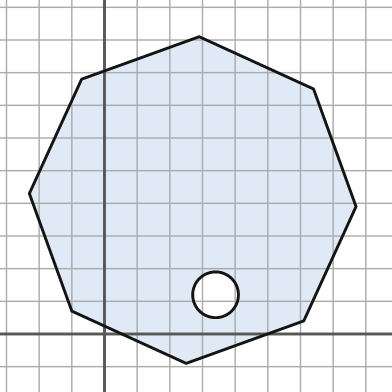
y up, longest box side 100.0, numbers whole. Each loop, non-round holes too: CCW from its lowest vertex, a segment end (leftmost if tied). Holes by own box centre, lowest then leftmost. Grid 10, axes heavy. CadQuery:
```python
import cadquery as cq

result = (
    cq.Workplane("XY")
    .moveTo(25.0, -9.0)
    .lineTo(61.0, 4.0)
    .lineTo(77.0, 39.0)
    .lineTo(64.0, 75.0)
    .lineTo(29.0, 91.0)
    .lineTo(-7.0, 78.0)
    .lineTo(-23.0, 43.0)
    .lineTo(-10.0, 7.0)
    .close()
    .moveTo(34.0, 12.0)
    .circle(7.0)
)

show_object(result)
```